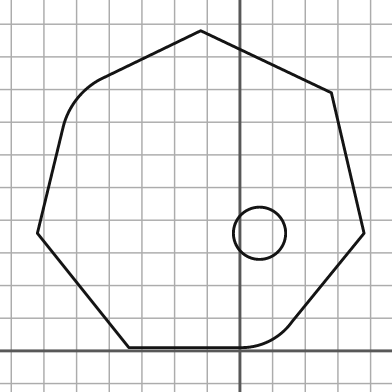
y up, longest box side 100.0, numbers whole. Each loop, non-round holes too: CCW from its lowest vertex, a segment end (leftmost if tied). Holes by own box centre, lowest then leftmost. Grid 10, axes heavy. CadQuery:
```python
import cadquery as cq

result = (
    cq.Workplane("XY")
    .moveTo(-34.0, 1.0)
    .lineTo(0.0, 1.0)
    .threePointArc((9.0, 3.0), (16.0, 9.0))
    .lineTo(38.0, 36.0)
    .lineTo(28.0, 79.0)
    .lineTo(-12.0, 98.0)
    .lineTo(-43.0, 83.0)
    .threePointArc((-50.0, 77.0), (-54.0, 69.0))
    .lineTo(-62.0, 36.0)
    .close()
    .moveTo(6.0, 36.0)
    .circle(8.0)
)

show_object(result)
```